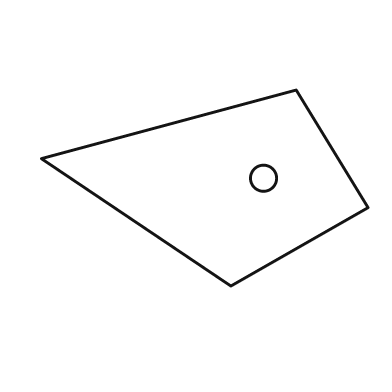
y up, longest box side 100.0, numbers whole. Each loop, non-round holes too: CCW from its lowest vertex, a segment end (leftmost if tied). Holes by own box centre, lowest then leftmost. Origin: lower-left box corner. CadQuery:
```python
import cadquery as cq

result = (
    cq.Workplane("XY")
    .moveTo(58.0, 0.0)
    .lineTo(100.0, 24.0)
    .lineTo(78.0, 60.0)
    .lineTo(0.0, 39.0)
    .close()
    .moveTo(68.0, 33.0)
    .circle(4.0)
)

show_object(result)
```